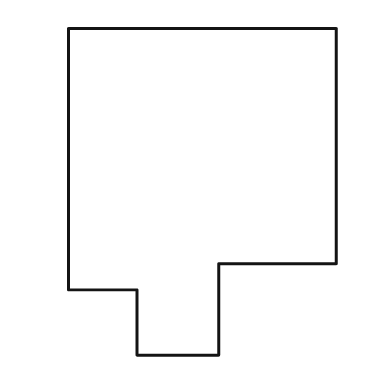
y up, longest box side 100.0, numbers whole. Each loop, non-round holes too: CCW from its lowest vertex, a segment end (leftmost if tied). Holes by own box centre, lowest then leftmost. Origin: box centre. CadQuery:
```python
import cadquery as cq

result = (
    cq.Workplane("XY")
    .moveTo(-20.0, -50.0)
    .lineTo(5.0, -50.0)
    .lineTo(5.0, -22.0)
    .lineTo(41.0, -22.0)
    .lineTo(41.0, 50.0)
    .lineTo(-41.0, 50.0)
    .lineTo(-41.0, -30.0)
    .lineTo(-20.0, -30.0)
    .close()
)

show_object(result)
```